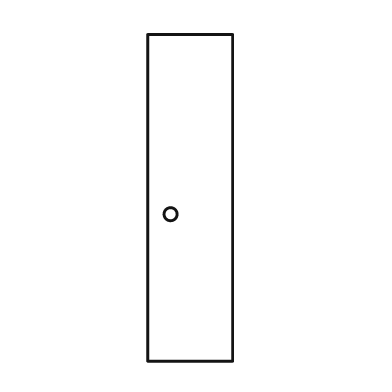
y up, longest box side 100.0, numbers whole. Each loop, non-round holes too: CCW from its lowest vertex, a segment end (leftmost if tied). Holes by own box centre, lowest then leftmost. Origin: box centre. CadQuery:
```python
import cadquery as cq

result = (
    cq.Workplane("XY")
    .moveTo(-13.0, -50.0)
    .lineTo(13.0, -50.0)
    .lineTo(13.0, 50.0)
    .lineTo(-13.0, 50.0)
    .close()
    .moveTo(-6.0, -5.0)
    .circle(2.0)
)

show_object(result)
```